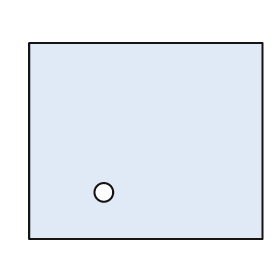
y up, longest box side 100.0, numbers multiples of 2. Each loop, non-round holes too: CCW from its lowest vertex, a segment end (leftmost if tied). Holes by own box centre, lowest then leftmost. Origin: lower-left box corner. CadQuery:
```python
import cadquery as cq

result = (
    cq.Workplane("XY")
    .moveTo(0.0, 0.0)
    .lineTo(100.0, 0.0)
    .lineTo(100.0, 84.0)
    .lineTo(0.0, 84.0)
    .close()
    .moveTo(32.0, 20.0)
    .circle(4.0)
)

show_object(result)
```